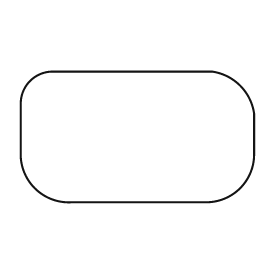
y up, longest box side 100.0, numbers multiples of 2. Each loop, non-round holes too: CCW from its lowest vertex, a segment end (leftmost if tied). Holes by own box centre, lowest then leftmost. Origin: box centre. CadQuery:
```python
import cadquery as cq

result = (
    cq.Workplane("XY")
    .moveTo(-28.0, -28.0)
    .lineTo(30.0, -28.0)
    .threePointArc((44.0, -22.0), (50.0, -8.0))
    .lineTo(50.0, 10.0)
    .threePointArc((44.0, 22.0), (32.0, 28.0))
    .lineTo(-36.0, 28.0)
    .threePointArc((-46.0, 24.0), (-50.0, 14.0))
    .lineTo(-50.0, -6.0)
    .threePointArc((-44.0, -22.0), (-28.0, -28.0))
    .close()
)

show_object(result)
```